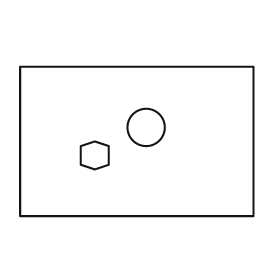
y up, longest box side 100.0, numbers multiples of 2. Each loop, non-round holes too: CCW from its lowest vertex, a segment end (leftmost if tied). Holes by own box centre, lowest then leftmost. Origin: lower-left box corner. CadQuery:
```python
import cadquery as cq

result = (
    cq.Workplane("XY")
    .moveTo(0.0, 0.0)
    .lineTo(100.0, 0.0)
    .lineTo(100.0, 64.0)
    .lineTo(0.0, 64.0)
    .close()
    .moveTo(32.0, 20.0)
    .lineTo(38.0, 22.0)
    .lineTo(38.0, 30.0)
    .lineTo(32.0, 32.0)
    .lineTo(26.0, 30.0)
    .lineTo(26.0, 22.0)
    .close()
    .moveTo(54.0, 38.0)
    .circle(8.0)
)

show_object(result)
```